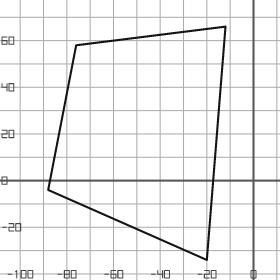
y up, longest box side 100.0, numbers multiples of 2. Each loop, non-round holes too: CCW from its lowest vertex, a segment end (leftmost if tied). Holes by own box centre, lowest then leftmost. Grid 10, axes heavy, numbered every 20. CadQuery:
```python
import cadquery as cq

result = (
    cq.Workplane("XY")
    .moveTo(-20.0, -34.0)
    .lineTo(-12.0, 66.0)
    .lineTo(-76.0, 58.0)
    .lineTo(-88.0, -4.0)
    .close()
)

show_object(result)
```